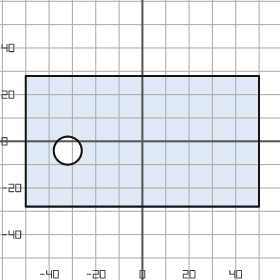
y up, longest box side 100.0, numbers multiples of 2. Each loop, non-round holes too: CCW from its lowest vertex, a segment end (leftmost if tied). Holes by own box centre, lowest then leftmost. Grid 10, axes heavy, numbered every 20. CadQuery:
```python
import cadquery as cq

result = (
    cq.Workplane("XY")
    .moveTo(-50.0, -28.0)
    .lineTo(50.0, -28.0)
    .lineTo(50.0, 28.0)
    .lineTo(-50.0, 28.0)
    .close()
    .moveTo(-32.0, -4.0)
    .circle(6.0)
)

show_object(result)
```